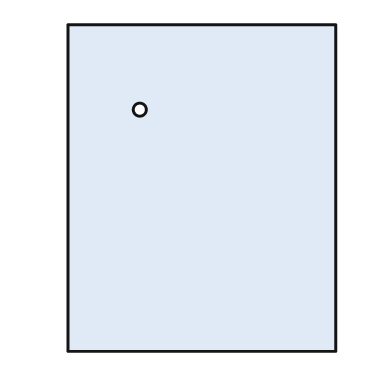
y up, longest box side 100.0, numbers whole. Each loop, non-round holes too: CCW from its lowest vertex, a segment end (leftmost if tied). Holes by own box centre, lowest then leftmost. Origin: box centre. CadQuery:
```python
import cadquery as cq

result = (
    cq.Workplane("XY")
    .moveTo(-41.0, -50.0)
    .lineTo(41.0, -50.0)
    .lineTo(41.0, 50.0)
    .lineTo(-41.0, 50.0)
    .close()
    .moveTo(-19.0, 24.0)
    .circle(2.0)
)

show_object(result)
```